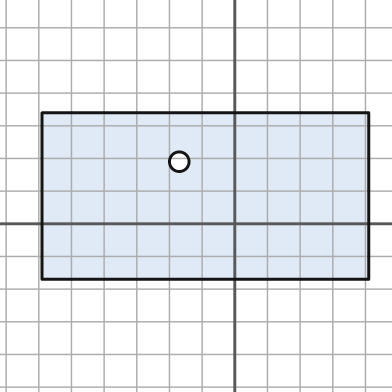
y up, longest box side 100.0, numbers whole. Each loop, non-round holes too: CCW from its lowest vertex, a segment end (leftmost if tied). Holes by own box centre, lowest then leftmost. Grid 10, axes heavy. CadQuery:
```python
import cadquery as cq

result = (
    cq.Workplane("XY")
    .moveTo(-59.0, -17.0)
    .lineTo(41.0, -17.0)
    .lineTo(41.0, 34.0)
    .lineTo(-59.0, 34.0)
    .close()
    .moveTo(-17.0, 19.0)
    .circle(3.0)
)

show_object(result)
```